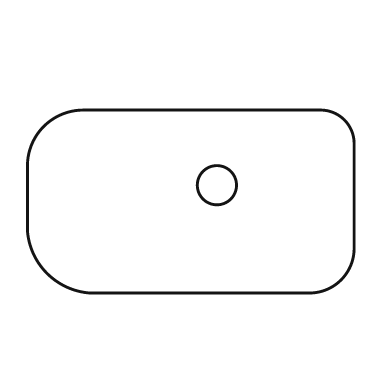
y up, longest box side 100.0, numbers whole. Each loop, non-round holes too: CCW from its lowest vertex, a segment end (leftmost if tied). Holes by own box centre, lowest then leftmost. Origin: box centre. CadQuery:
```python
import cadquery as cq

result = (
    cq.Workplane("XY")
    .moveTo(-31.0, -28.0)
    .lineTo(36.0, -28.0)
    .threePointArc((46.0, -24.0), (50.0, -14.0))
    .lineTo(50.0, 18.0)
    .threePointArc((47.0, 25.0), (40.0, 28.0))
    .lineTo(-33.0, 28.0)
    .threePointArc((-45.0, 23.0), (-50.0, 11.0))
    .lineTo(-50.0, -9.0)
    .threePointArc((-44.0, -22.0), (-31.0, -28.0))
    .close()
    .moveTo(8.0, 5.0)
    .circle(6.0)
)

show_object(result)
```